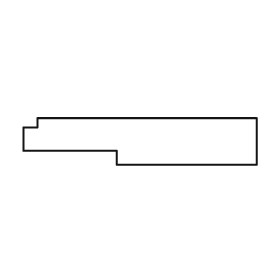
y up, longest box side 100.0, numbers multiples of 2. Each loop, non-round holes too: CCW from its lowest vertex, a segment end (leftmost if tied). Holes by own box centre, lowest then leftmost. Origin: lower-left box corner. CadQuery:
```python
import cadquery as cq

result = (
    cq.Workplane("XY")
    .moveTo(40.0, 0.0)
    .lineTo(100.0, 0.0)
    .lineTo(100.0, 20.0)
    .lineTo(6.0, 20.0)
    .lineTo(6.0, 16.0)
    .lineTo(0.0, 16.0)
    .lineTo(0.0, 6.0)
    .lineTo(40.0, 6.0)
    .close()
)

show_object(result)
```